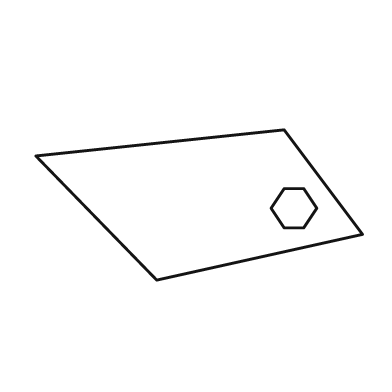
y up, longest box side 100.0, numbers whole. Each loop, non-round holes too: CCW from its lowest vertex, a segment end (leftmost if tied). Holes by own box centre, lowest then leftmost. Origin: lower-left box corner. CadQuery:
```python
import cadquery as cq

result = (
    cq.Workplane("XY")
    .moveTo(37.0, 0.0)
    .lineTo(100.0, 14.0)
    .lineTo(76.0, 46.0)
    .lineTo(0.0, 38.0)
    .close()
    .moveTo(76.0, 16.0)
    .lineTo(82.0, 16.0)
    .lineTo(86.0, 22.0)
    .lineTo(82.0, 28.0)
    .lineTo(76.0, 28.0)
    .lineTo(72.0, 22.0)
    .close()
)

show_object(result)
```